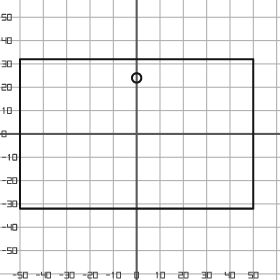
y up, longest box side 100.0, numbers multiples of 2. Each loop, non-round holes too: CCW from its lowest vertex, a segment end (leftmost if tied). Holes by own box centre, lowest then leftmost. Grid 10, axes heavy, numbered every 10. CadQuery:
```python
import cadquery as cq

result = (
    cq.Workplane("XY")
    .moveTo(-50.0, -32.0)
    .lineTo(50.0, -32.0)
    .lineTo(50.0, 32.0)
    .lineTo(-50.0, 32.0)
    .close()
    .moveTo(0.0, 24.0)
    .circle(2.0)
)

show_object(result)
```